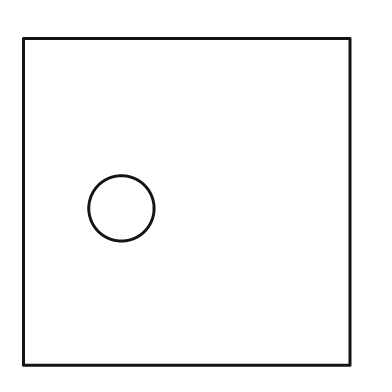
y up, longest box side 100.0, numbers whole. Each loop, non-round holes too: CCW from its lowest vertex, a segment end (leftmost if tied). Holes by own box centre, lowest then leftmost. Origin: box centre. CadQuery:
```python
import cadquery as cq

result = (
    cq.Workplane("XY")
    .moveTo(-50.0, -50.0)
    .lineTo(50.0, -50.0)
    .lineTo(50.0, 50.0)
    .lineTo(-50.0, 50.0)
    .close()
    .moveTo(-20.0, -2.0)
    .circle(10.0)
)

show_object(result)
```